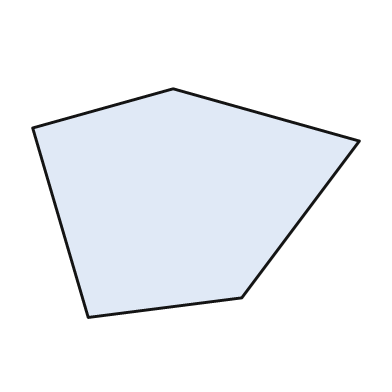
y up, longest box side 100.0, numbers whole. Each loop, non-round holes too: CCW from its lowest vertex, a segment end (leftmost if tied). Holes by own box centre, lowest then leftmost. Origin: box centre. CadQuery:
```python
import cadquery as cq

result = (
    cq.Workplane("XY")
    .moveTo(-33.0, -35.0)
    .lineTo(14.0, -29.0)
    .lineTo(50.0, 19.0)
    .lineTo(-7.0, 35.0)
    .lineTo(-50.0, 23.0)
    .close()
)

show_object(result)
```